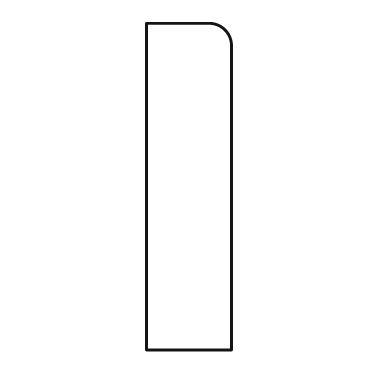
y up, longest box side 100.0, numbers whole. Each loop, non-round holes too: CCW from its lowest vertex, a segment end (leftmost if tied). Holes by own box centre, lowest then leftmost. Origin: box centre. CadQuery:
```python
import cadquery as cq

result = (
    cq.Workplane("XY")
    .moveTo(-13.0, -50.0)
    .lineTo(13.0, -50.0)
    .lineTo(13.0, 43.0)
    .threePointArc((11.0, 48.0), (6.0, 50.0))
    .lineTo(-13.0, 50.0)
    .close()
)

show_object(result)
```